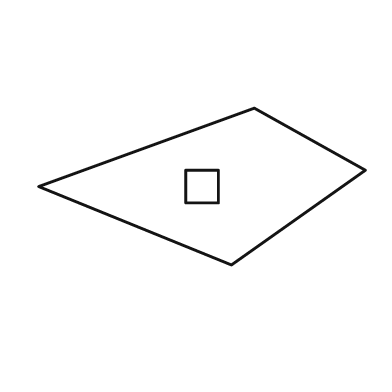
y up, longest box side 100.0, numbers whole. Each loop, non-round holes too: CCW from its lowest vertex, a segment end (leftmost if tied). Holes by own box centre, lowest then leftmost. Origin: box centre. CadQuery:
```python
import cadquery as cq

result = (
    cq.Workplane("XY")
    .moveTo(9.0, -24.0)
    .lineTo(50.0, 5.0)
    .lineTo(16.0, 24.0)
    .lineTo(-50.0, 0.0)
    .close()
    .moveTo(-5.0, -5.0)
    .lineTo(5.0, -5.0)
    .lineTo(5.0, 5.0)
    .lineTo(-5.0, 5.0)
    .close()
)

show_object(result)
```